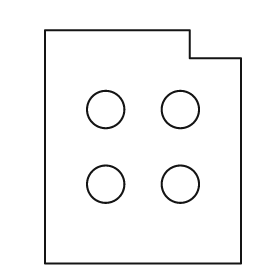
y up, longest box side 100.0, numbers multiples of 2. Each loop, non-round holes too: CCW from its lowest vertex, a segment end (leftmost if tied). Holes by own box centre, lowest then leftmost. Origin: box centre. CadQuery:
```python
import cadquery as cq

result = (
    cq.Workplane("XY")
    .moveTo(-42.0, -50.0)
    .lineTo(42.0, -50.0)
    .lineTo(42.0, 38.0)
    .lineTo(20.0, 38.0)
    .lineTo(20.0, 50.0)
    .lineTo(-42.0, 50.0)
    .close()
    .moveTo(-16.0, -16.0)
    .circle(8.0)
    .moveTo(16.0, -16.0)
    .circle(8.0)
    .moveTo(-16.0, 16.0)
    .circle(8.0)
    .moveTo(16.0, 16.0)
    .circle(8.0)
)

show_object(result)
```